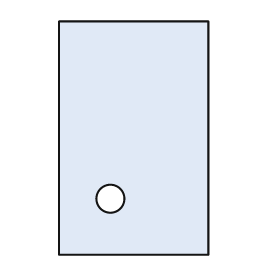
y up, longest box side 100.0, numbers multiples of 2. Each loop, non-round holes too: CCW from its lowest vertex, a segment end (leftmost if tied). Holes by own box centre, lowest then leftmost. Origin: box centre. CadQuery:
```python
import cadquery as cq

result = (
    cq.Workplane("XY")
    .moveTo(-32.0, -50.0)
    .lineTo(32.0, -50.0)
    .lineTo(32.0, 50.0)
    .lineTo(-32.0, 50.0)
    .close()
    .moveTo(-10.0, -26.0)
    .circle(6.0)
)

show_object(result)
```